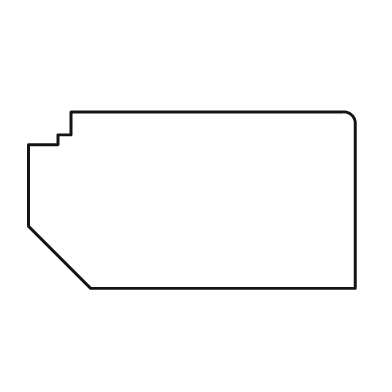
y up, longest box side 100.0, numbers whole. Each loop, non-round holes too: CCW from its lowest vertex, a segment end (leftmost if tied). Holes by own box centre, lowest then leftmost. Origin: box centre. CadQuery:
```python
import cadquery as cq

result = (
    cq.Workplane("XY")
    .moveTo(-31.0, -27.0)
    .lineTo(50.0, -27.0)
    .lineTo(50.0, 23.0)
    .threePointArc((49.0, 26.0), (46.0, 27.0))
    .lineTo(-37.0, 27.0)
    .lineTo(-37.0, 20.0)
    .lineTo(-41.0, 20.0)
    .lineTo(-41.0, 17.0)
    .lineTo(-50.0, 17.0)
    .lineTo(-50.0, -8.0)
    .close()
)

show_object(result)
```